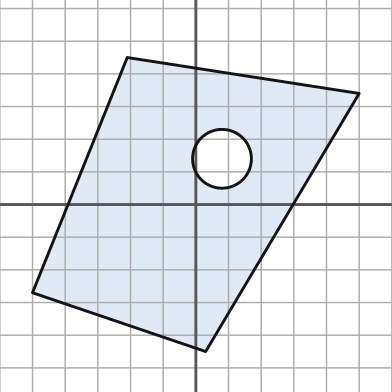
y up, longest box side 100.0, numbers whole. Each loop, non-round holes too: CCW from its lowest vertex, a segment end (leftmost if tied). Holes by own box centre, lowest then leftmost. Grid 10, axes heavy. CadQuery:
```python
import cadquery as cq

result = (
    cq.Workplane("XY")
    .moveTo(3.0, -45.0)
    .lineTo(50.0, 34.0)
    .lineTo(-21.0, 45.0)
    .lineTo(-50.0, -27.0)
    .close()
    .moveTo(8.0, 14.0)
    .circle(9.0)
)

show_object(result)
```